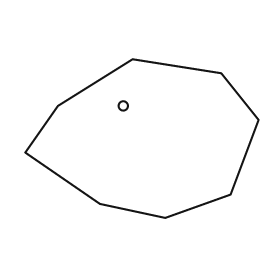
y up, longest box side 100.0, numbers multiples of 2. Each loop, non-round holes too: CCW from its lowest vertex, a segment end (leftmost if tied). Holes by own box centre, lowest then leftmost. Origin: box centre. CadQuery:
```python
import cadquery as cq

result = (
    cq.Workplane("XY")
    .moveTo(10.0, -34.0)
    .lineTo(38.0, -24.0)
    .lineTo(50.0, 8.0)
    .lineTo(34.0, 28.0)
    .lineTo(-4.0, 34.0)
    .lineTo(-36.0, 14.0)
    .lineTo(-50.0, -6.0)
    .lineTo(-18.0, -28.0)
    .close()
    .moveTo(-8.0, 14.0)
    .circle(2.0)
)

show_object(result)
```